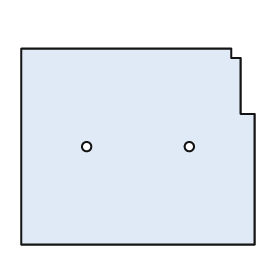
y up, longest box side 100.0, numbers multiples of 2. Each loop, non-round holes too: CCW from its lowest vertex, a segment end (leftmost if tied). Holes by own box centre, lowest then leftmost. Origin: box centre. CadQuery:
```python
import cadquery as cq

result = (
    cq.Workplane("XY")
    .moveTo(-50.0, -42.0)
    .lineTo(50.0, -42.0)
    .lineTo(50.0, 14.0)
    .lineTo(44.0, 14.0)
    .lineTo(44.0, 38.0)
    .lineTo(40.0, 38.0)
    .lineTo(40.0, 42.0)
    .lineTo(-50.0, 42.0)
    .close()
    .moveTo(-22.0, 0.0)
    .circle(2.0)
    .moveTo(22.0, 0.0)
    .circle(2.0)
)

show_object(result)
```